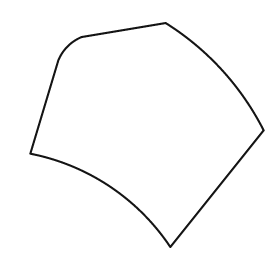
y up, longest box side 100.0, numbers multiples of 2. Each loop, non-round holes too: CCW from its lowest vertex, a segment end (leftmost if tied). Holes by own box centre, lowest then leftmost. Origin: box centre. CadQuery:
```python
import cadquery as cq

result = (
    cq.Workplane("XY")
    .moveTo(10.0, -48.0)
    .lineTo(50.0, 2.0)
    .threePointArc((32.0, 28.0), (8.0, 48.0))
    .lineTo(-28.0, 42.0)
    .threePointArc((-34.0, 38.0), (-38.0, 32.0))
    .lineTo(-50.0, -8.0)
    .threePointArc((-16.0, -22.0), (10.0, -48.0))
    .close()
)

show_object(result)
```